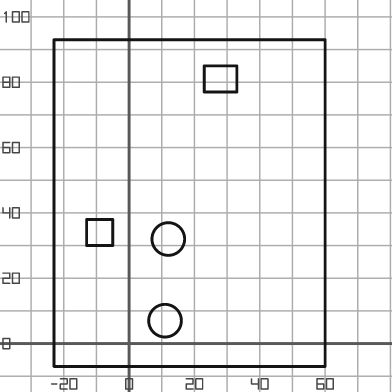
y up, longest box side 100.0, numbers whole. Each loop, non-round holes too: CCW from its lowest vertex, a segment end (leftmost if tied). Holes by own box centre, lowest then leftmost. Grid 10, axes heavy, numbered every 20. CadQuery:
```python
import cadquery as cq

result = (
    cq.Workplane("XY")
    .moveTo(-23.0, -7.0)
    .lineTo(60.0, -7.0)
    .lineTo(60.0, 93.0)
    .lineTo(-23.0, 93.0)
    .close()
    .moveTo(11.0, 7.0)
    .circle(5.0)
    .moveTo(12.0, 32.0)
    .circle(5.0)
    .moveTo(-13.0, 30.0)
    .lineTo(-5.0, 30.0)
    .lineTo(-5.0, 38.0)
    .lineTo(-13.0, 38.0)
    .close()
    .moveTo(23.0, 77.0)
    .lineTo(33.0, 77.0)
    .lineTo(33.0, 85.0)
    .lineTo(23.0, 85.0)
    .close()
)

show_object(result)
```